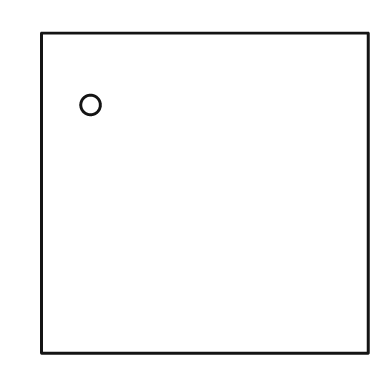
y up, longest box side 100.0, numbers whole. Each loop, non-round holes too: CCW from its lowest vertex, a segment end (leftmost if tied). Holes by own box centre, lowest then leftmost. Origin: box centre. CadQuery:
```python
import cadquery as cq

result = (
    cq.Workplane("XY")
    .moveTo(-50.0, -49.0)
    .lineTo(50.0, -49.0)
    .lineTo(50.0, 49.0)
    .lineTo(-50.0, 49.0)
    .close()
    .moveTo(-35.0, 27.0)
    .circle(3.0)
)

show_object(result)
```